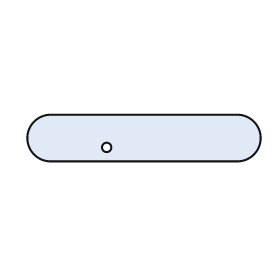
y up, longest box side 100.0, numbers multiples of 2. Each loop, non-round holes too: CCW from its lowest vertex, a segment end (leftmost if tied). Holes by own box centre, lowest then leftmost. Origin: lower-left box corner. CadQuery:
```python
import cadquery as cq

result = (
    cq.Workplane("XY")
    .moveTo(10.0, 0.0)
    .lineTo(90.0, 0.0)
    .threePointArc((100.0, 10.0), (90.0, 20.0))
    .lineTo(10.0, 20.0)
    .threePointArc((0.0, 10.0), (10.0, 0.0))
    .close()
    .moveTo(34.0, 6.0)
    .circle(2.0)
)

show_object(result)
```